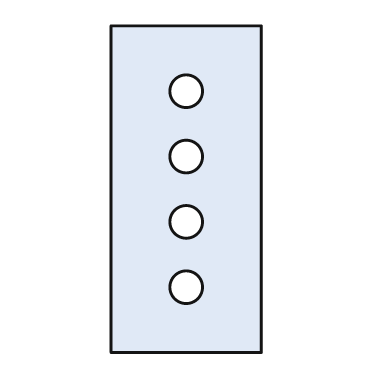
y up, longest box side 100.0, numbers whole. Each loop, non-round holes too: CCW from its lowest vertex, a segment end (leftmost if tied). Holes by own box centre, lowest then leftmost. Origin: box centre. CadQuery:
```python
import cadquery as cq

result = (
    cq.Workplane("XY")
    .moveTo(-23.0, -50.0)
    .lineTo(23.0, -50.0)
    .lineTo(23.0, 50.0)
    .lineTo(-23.0, 50.0)
    .close()
    .moveTo(0.0, -30.0)
    .circle(5.0)
    .moveTo(0.0, -10.0)
    .circle(5.0)
    .moveTo(0.0, 10.0)
    .circle(5.0)
    .moveTo(0.0, 30.0)
    .circle(5.0)
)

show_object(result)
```